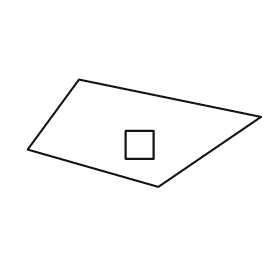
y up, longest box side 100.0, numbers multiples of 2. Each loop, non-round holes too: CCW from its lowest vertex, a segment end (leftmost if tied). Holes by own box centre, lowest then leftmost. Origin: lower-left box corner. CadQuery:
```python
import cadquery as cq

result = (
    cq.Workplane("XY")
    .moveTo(56.0, 0.0)
    .lineTo(100.0, 30.0)
    .lineTo(22.0, 46.0)
    .lineTo(0.0, 16.0)
    .close()
    .moveTo(42.0, 12.0)
    .lineTo(54.0, 12.0)
    .lineTo(54.0, 24.0)
    .lineTo(42.0, 24.0)
    .close()
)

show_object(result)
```